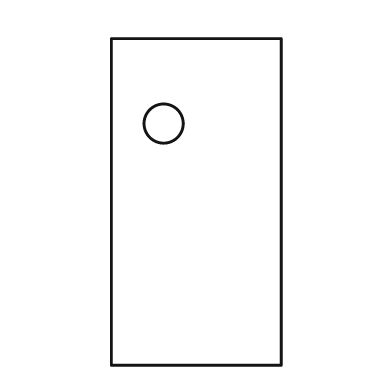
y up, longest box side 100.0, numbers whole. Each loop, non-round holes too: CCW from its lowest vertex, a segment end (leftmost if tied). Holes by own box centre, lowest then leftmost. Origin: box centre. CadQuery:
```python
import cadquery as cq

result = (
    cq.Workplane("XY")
    .moveTo(-26.0, -50.0)
    .lineTo(26.0, -50.0)
    .lineTo(26.0, 50.0)
    .lineTo(-26.0, 50.0)
    .close()
    .moveTo(-10.0, 24.0)
    .circle(6.0)
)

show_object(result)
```